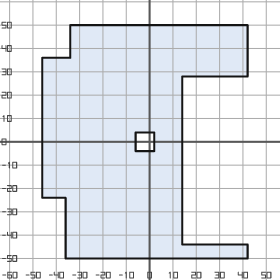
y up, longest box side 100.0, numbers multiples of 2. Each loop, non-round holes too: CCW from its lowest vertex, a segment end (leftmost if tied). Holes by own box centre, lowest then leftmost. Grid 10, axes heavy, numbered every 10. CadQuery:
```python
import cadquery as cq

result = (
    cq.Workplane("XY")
    .moveTo(-36.0, -50.0)
    .lineTo(42.0, -50.0)
    .lineTo(42.0, -44.0)
    .lineTo(14.0, -44.0)
    .lineTo(14.0, 28.0)
    .lineTo(42.0, 28.0)
    .lineTo(42.0, 50.0)
    .lineTo(-34.0, 50.0)
    .lineTo(-34.0, 36.0)
    .lineTo(-46.0, 36.0)
    .lineTo(-46.0, -24.0)
    .lineTo(-36.0, -24.0)
    .close()
    .moveTo(-6.0, -4.0)
    .lineTo(2.0, -4.0)
    .lineTo(2.0, 4.0)
    .lineTo(-6.0, 4.0)
    .close()
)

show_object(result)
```